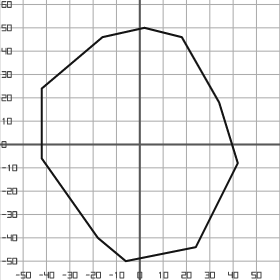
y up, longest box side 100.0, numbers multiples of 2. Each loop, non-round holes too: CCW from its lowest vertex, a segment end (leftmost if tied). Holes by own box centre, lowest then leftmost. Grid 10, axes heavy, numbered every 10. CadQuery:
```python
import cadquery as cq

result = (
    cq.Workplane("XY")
    .moveTo(-6.0, -50.0)
    .lineTo(24.0, -44.0)
    .lineTo(42.0, -8.0)
    .lineTo(34.0, 18.0)
    .lineTo(18.0, 46.0)
    .lineTo(2.0, 50.0)
    .lineTo(-16.0, 46.0)
    .lineTo(-42.0, 24.0)
    .lineTo(-42.0, -6.0)
    .lineTo(-18.0, -40.0)
    .close()
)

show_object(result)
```